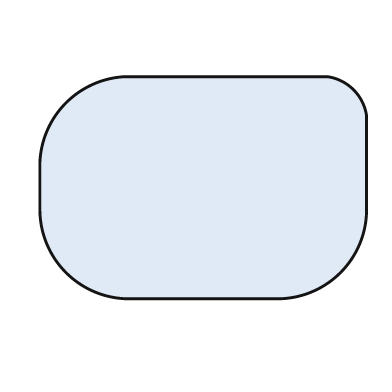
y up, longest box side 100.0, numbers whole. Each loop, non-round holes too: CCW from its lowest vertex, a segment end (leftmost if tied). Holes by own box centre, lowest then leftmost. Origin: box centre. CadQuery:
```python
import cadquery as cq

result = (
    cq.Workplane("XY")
    .moveTo(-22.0, -34.0)
    .lineTo(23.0, -34.0)
    .threePointArc((42.0, -26.0), (50.0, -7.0))
    .lineTo(50.0, 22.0)
    .threePointArc((46.0, 30.0), (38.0, 34.0))
    .lineTo(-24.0, 34.0)
    .threePointArc((-42.0, 26.0), (-50.0, 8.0))
    .lineTo(-50.0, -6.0)
    .threePointArc((-42.0, -26.0), (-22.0, -34.0))
    .close()
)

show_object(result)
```